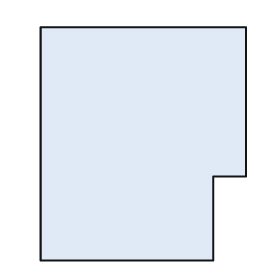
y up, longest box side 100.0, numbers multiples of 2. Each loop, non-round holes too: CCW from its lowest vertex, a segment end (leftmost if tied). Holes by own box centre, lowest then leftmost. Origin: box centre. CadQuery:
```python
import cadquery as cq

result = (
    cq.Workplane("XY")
    .moveTo(-44.0, -50.0)
    .lineTo(30.0, -50.0)
    .lineTo(30.0, -14.0)
    .lineTo(44.0, -14.0)
    .lineTo(44.0, 50.0)
    .lineTo(-44.0, 50.0)
    .close()
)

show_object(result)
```